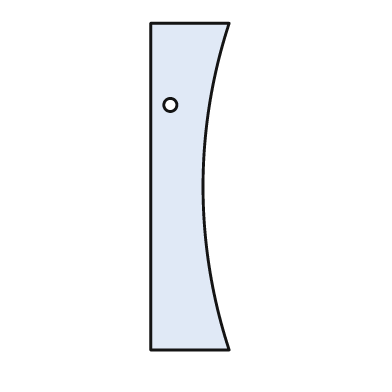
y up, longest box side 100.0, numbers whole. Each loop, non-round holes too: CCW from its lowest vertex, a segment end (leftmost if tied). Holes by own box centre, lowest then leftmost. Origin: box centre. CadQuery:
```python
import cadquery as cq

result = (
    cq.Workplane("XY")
    .moveTo(-12.0, -50.0)
    .lineTo(12.0, -50.0)
    .threePointArc((4.0, 0.0), (12.0, 50.0))
    .lineTo(-12.0, 50.0)
    .close()
    .moveTo(-6.0, 25.0)
    .circle(2.0)
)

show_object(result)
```